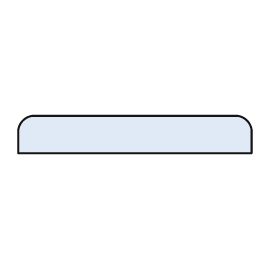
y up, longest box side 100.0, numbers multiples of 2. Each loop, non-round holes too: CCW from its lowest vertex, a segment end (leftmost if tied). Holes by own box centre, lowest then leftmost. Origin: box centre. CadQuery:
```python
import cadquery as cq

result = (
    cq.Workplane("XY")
    .moveTo(-50.0, -8.0)
    .lineTo(50.0, -8.0)
    .lineTo(50.0, 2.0)
    .threePointArc((48.0, 6.0), (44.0, 8.0))
    .lineTo(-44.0, 8.0)
    .threePointArc((-48.0, 6.0), (-50.0, 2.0))
    .close()
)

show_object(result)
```